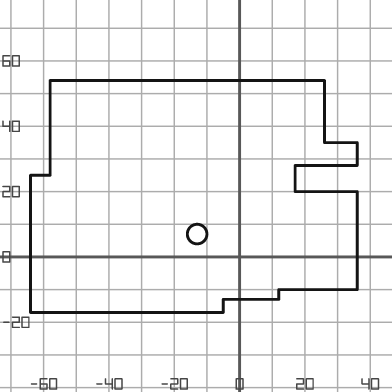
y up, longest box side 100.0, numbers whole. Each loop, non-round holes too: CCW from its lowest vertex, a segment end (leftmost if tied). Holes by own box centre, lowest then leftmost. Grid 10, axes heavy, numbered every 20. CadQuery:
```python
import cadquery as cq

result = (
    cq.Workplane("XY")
    .moveTo(-64.0, -17.0)
    .lineTo(-5.0, -17.0)
    .lineTo(-5.0, -13.0)
    .lineTo(12.0, -13.0)
    .lineTo(12.0, -10.0)
    .lineTo(36.0, -10.0)
    .lineTo(36.0, 20.0)
    .lineTo(17.0, 20.0)
    .lineTo(17.0, 28.0)
    .lineTo(36.0, 28.0)
    .lineTo(36.0, 35.0)
    .lineTo(26.0, 35.0)
    .lineTo(26.0, 54.0)
    .lineTo(-58.0, 54.0)
    .lineTo(-58.0, 25.0)
    .lineTo(-64.0, 25.0)
    .close()
    .moveTo(-13.0, 7.0)
    .circle(3.0)
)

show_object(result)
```